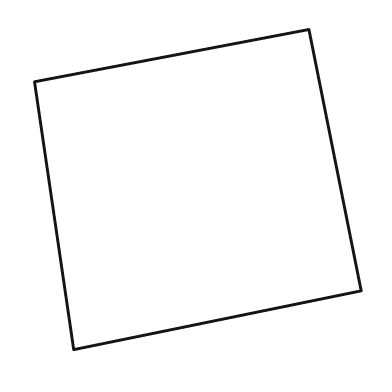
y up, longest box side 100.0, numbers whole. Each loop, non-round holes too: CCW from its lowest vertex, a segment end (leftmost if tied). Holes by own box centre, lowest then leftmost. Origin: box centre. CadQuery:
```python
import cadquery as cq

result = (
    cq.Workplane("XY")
    .moveTo(-38.0, -49.0)
    .lineTo(50.0, -31.0)
    .lineTo(34.0, 49.0)
    .lineTo(-50.0, 33.0)
    .close()
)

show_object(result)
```